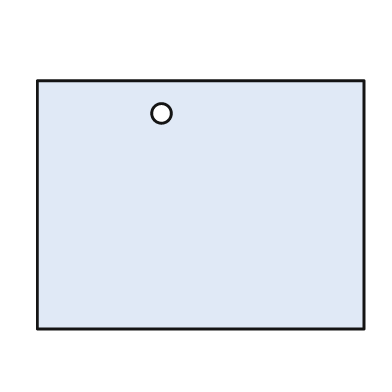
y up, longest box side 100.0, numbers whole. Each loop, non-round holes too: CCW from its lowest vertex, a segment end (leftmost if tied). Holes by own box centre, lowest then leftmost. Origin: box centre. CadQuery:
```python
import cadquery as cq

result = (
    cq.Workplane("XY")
    .moveTo(-50.0, -38.0)
    .lineTo(50.0, -38.0)
    .lineTo(50.0, 38.0)
    .lineTo(-50.0, 38.0)
    .close()
    .moveTo(-12.0, 28.0)
    .circle(3.0)
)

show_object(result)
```